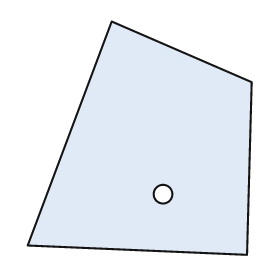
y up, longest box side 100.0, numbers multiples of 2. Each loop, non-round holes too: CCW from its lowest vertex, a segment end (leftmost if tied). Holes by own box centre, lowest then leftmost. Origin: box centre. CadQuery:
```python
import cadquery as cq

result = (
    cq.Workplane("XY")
    .moveTo(46.0, -50.0)
    .lineTo(48.0, 24.0)
    .lineTo(-12.0, 50.0)
    .lineTo(-48.0, -46.0)
    .close()
    .moveTo(10.0, -24.0)
    .circle(4.0)
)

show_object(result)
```